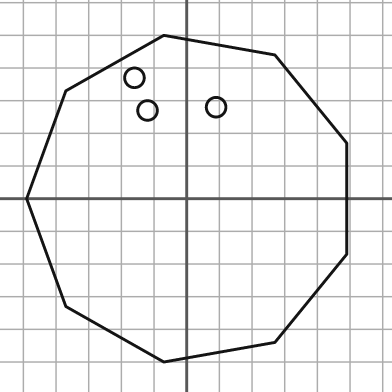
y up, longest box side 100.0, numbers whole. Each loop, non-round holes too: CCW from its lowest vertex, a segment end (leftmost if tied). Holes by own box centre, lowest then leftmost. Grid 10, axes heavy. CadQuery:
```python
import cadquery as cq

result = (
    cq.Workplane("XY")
    .moveTo(-7.0, -50.0)
    .lineTo(27.0, -44.0)
    .lineTo(49.0, -17.0)
    .lineTo(49.0, 17.0)
    .lineTo(27.0, 44.0)
    .lineTo(-7.0, 50.0)
    .lineTo(-37.0, 33.0)
    .lineTo(-49.0, 0.0)
    .lineTo(-37.0, -33.0)
    .close()
    .moveTo(-12.0, 27.0)
    .circle(3.0)
    .moveTo(9.0, 28.0)
    .circle(3.0)
    .moveTo(-16.0, 37.0)
    .circle(3.0)
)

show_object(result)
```